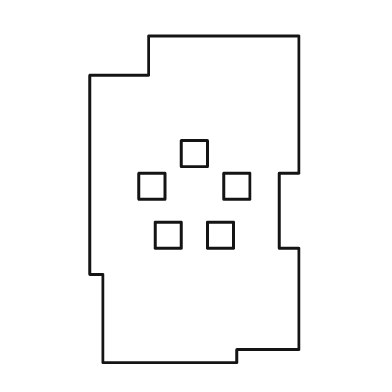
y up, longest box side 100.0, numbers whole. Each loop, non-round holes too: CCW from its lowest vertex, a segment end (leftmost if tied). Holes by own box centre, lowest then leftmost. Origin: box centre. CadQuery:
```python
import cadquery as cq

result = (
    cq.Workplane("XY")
    .moveTo(-28.0, -50.0)
    .lineTo(13.0, -50.0)
    .lineTo(13.0, -46.0)
    .lineTo(32.0, -46.0)
    .lineTo(32.0, -15.0)
    .lineTo(26.0, -15.0)
    .lineTo(26.0, 8.0)
    .lineTo(32.0, 8.0)
    .lineTo(32.0, 50.0)
    .lineTo(-14.0, 50.0)
    .lineTo(-14.0, 38.0)
    .lineTo(-32.0, 38.0)
    .lineTo(-32.0, -23.0)
    .lineTo(-28.0, -23.0)
    .close()
    .moveTo(-12.0, -15.0)
    .lineTo(-4.0, -15.0)
    .lineTo(-4.0, -7.0)
    .lineTo(-12.0, -7.0)
    .close()
    .moveTo(4.0, -15.0)
    .lineTo(12.0, -15.0)
    .lineTo(12.0, -7.0)
    .lineTo(4.0, -7.0)
    .close()
    .moveTo(-17.0, 0.0)
    .lineTo(-9.0, 0.0)
    .lineTo(-9.0, 8.0)
    .lineTo(-17.0, 8.0)
    .close()
    .moveTo(9.0, 0.0)
    .lineTo(17.0, 0.0)
    .lineTo(17.0, 8.0)
    .lineTo(9.0, 8.0)
    .close()
    .moveTo(-4.0, 10.0)
    .lineTo(4.0, 10.0)
    .lineTo(4.0, 18.0)
    .lineTo(-4.0, 18.0)
    .close()
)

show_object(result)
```